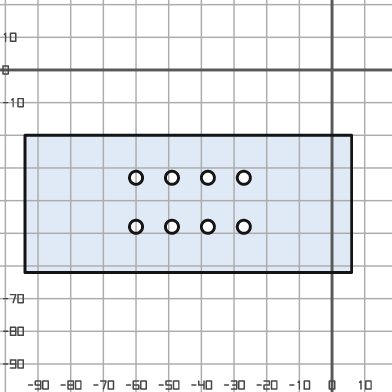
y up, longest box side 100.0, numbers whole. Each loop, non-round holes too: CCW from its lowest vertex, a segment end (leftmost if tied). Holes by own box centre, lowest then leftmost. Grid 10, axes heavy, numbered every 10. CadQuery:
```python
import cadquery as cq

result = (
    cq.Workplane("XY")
    .moveTo(-94.0, -62.0)
    .lineTo(6.0, -62.0)
    .lineTo(6.0, -20.0)
    .lineTo(-94.0, -20.0)
    .close()
    .moveTo(-60.0, -48.0)
    .circle(2.0)
    .moveTo(-49.0, -48.0)
    .circle(2.0)
    .moveTo(-38.0, -48.0)
    .circle(2.0)
    .moveTo(-27.0, -48.0)
    .circle(2.0)
    .moveTo(-60.0, -33.0)
    .circle(2.0)
    .moveTo(-49.0, -33.0)
    .circle(2.0)
    .moveTo(-38.0, -33.0)
    .circle(2.0)
    .moveTo(-27.0, -33.0)
    .circle(2.0)
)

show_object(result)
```